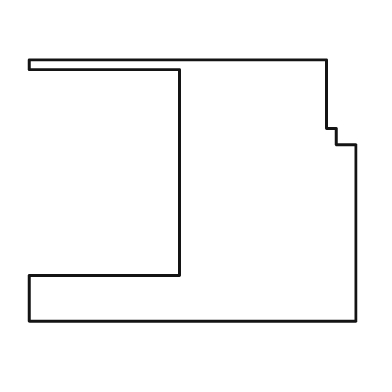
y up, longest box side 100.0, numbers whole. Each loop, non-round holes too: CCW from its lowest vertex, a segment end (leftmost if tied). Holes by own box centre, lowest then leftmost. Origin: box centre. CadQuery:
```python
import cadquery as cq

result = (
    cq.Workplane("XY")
    .moveTo(-50.0, -40.0)
    .lineTo(50.0, -40.0)
    .lineTo(50.0, 14.0)
    .lineTo(44.0, 14.0)
    .lineTo(44.0, 19.0)
    .lineTo(41.0, 19.0)
    .lineTo(41.0, 40.0)
    .lineTo(-50.0, 40.0)
    .lineTo(-50.0, 37.0)
    .lineTo(-4.0, 37.0)
    .lineTo(-4.0, -26.0)
    .lineTo(-50.0, -26.0)
    .close()
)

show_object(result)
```